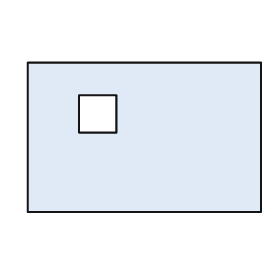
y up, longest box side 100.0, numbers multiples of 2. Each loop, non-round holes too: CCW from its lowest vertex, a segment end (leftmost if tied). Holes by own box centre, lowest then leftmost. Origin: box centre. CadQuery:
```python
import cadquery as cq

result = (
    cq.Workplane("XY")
    .moveTo(-50.0, -32.0)
    .lineTo(50.0, -32.0)
    .lineTo(50.0, 32.0)
    .lineTo(-50.0, 32.0)
    .close()
    .moveTo(-28.0, 2.0)
    .lineTo(-12.0, 2.0)
    .lineTo(-12.0, 18.0)
    .lineTo(-28.0, 18.0)
    .close()
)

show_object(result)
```